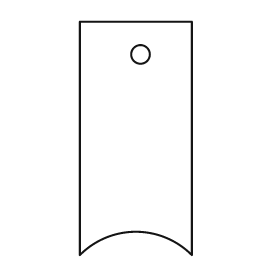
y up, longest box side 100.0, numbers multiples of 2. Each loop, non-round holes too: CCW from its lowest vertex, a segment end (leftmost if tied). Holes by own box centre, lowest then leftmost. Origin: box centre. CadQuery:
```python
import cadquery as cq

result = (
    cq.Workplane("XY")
    .moveTo(-24.0, -50.0)
    .threePointArc((0.0, -40.0), (24.0, -50.0))
    .lineTo(24.0, 50.0)
    .lineTo(-24.0, 50.0)
    .close()
    .moveTo(2.0, 36.0)
    .circle(4.0)
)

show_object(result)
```